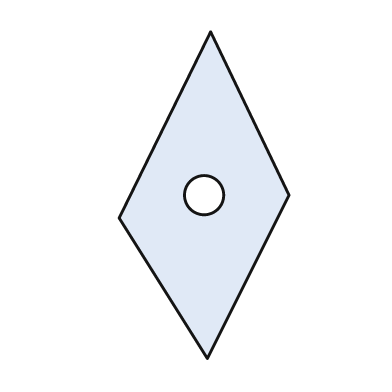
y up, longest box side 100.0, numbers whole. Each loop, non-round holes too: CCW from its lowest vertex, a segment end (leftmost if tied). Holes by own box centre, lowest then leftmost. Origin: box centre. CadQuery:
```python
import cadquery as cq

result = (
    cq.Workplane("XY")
    .moveTo(1.0, -50.0)
    .lineTo(26.0, 0.0)
    .lineTo(2.0, 50.0)
    .lineTo(-26.0, -7.0)
    .close()
    .moveTo(0.0, 0.0)
    .circle(6.0)
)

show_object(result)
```